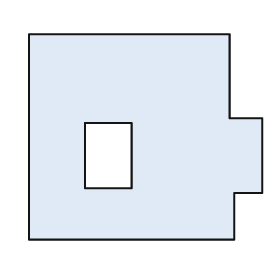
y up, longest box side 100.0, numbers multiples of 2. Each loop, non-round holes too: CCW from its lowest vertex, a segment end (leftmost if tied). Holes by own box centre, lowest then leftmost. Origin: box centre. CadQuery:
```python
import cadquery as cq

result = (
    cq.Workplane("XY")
    .moveTo(-50.0, -44.0)
    .lineTo(38.0, -44.0)
    .lineTo(38.0, -24.0)
    .lineTo(50.0, -24.0)
    .lineTo(50.0, 8.0)
    .lineTo(36.0, 8.0)
    .lineTo(36.0, 44.0)
    .lineTo(-50.0, 44.0)
    .close()
    .moveTo(-26.0, -22.0)
    .lineTo(-6.0, -22.0)
    .lineTo(-6.0, 6.0)
    .lineTo(-26.0, 6.0)
    .close()
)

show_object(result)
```